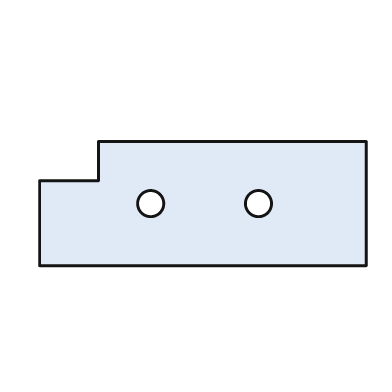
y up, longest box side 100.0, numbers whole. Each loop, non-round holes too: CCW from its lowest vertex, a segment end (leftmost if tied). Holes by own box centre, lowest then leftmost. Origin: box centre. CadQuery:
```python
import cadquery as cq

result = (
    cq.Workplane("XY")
    .moveTo(-50.0, -19.0)
    .lineTo(50.0, -19.0)
    .lineTo(50.0, 19.0)
    .lineTo(-32.0, 19.0)
    .lineTo(-32.0, 7.0)
    .lineTo(-50.0, 7.0)
    .close()
    .moveTo(-16.0, 0.0)
    .circle(4.0)
    .moveTo(17.0, 0.0)
    .circle(4.0)
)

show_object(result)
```